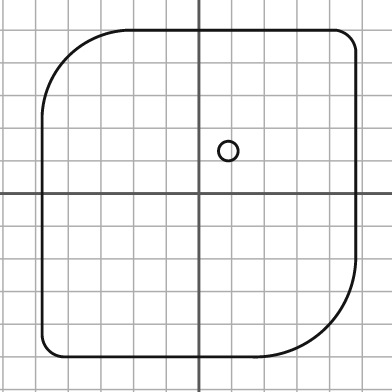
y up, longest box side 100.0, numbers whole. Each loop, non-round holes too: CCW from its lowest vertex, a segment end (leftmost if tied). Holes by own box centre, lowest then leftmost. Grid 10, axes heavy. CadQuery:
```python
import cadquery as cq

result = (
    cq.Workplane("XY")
    .moveTo(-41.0, -50.0)
    .lineTo(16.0, -50.0)
    .threePointArc((39.0, -41.0), (48.0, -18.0))
    .lineTo(48.0, 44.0)
    .threePointArc((46.0, 48.0), (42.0, 50.0))
    .lineTo(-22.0, 50.0)
    .threePointArc((-40.0, 42.0), (-48.0, 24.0))
    .lineTo(-48.0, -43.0)
    .threePointArc((-46.0, -48.0), (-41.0, -50.0))
    .close()
    .moveTo(9.0, 13.0)
    .circle(3.0)
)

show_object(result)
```